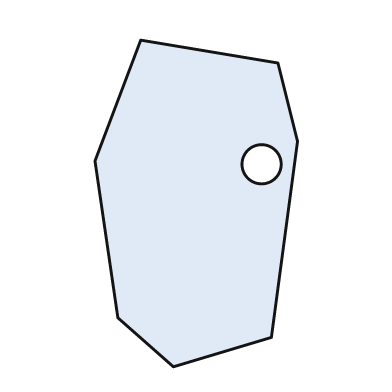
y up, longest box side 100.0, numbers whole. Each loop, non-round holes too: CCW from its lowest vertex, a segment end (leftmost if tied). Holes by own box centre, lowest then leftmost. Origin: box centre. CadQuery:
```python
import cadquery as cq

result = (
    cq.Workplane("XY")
    .moveTo(-7.0, -50.0)
    .lineTo(23.0, -41.0)
    .lineTo(31.0, 19.0)
    .lineTo(25.0, 43.0)
    .lineTo(-17.0, 50.0)
    .lineTo(-31.0, 13.0)
    .lineTo(-24.0, -35.0)
    .close()
    .moveTo(20.0, 12.0)
    .circle(6.0)
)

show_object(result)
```